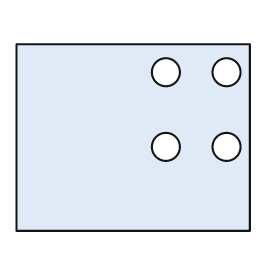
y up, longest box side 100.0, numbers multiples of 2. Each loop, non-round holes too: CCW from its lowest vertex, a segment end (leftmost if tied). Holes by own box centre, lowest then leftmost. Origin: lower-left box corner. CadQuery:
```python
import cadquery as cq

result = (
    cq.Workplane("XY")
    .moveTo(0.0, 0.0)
    .lineTo(100.0, 0.0)
    .lineTo(100.0, 80.0)
    .lineTo(0.0, 80.0)
    .close()
    .moveTo(64.0, 36.0)
    .circle(6.0)
    .moveTo(90.0, 36.0)
    .circle(6.0)
    .moveTo(64.0, 68.0)
    .circle(6.0)
    .moveTo(90.0, 68.0)
    .circle(6.0)
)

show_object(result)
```